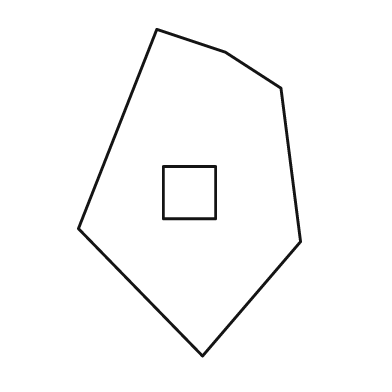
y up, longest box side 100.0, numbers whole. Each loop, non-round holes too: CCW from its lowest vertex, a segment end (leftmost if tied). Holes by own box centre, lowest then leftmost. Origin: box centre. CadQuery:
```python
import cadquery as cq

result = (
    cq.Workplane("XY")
    .moveTo(4.0, -50.0)
    .lineTo(34.0, -15.0)
    .lineTo(28.0, 32.0)
    .lineTo(11.0, 43.0)
    .lineTo(-10.0, 50.0)
    .lineTo(-34.0, -11.0)
    .close()
    .moveTo(-8.0, -8.0)
    .lineTo(8.0, -8.0)
    .lineTo(8.0, 8.0)
    .lineTo(-8.0, 8.0)
    .close()
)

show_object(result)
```